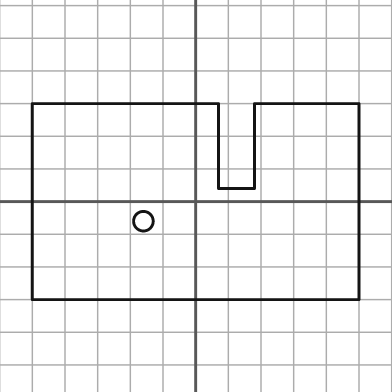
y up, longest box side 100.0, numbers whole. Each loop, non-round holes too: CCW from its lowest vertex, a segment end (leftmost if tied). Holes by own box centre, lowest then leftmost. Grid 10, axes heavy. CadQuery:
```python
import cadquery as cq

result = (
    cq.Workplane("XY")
    .moveTo(-50.0, -30.0)
    .lineTo(50.0, -30.0)
    .lineTo(50.0, 30.0)
    .lineTo(18.0, 30.0)
    .lineTo(18.0, 4.0)
    .lineTo(7.0, 4.0)
    .lineTo(7.0, 30.0)
    .lineTo(-50.0, 30.0)
    .close()
    .moveTo(-16.0, -6.0)
    .circle(3.0)
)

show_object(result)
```